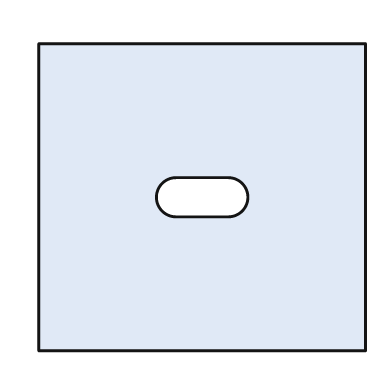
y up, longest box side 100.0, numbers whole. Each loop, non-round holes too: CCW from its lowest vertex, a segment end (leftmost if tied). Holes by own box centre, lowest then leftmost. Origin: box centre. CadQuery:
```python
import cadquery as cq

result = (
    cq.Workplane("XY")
    .moveTo(-50.0, -47.0)
    .lineTo(50.0, -47.0)
    .lineTo(50.0, 47.0)
    .lineTo(-50.0, 47.0)
    .close()
    .moveTo(-8.0, -6.0)
    .lineTo(8.0, -6.0)
    .threePointArc((14.0, 0.0), (8.0, 6.0))
    .lineTo(-8.0, 6.0)
    .threePointArc((-14.0, 0.0), (-8.0, -6.0))
    .close()
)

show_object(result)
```